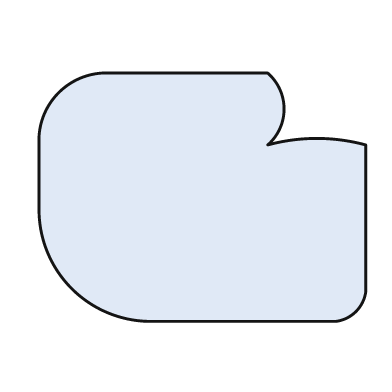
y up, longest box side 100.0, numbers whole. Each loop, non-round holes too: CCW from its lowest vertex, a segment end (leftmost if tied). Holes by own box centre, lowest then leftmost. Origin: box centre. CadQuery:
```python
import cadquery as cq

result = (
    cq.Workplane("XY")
    .moveTo(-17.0, -38.0)
    .lineTo(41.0, -38.0)
    .threePointArc((47.0, -35.0), (50.0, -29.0))
    .lineTo(50.0, 16.0)
    .threePointArc((35.0, 18.0), (20.0, 16.0))
    .threePointArc((25.0, 27.0), (20.0, 38.0))
    .lineTo(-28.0, 38.0)
    .threePointArc((-44.0, 32.0), (-50.0, 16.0))
    .lineTo(-50.0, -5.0)
    .threePointArc((-40.0, -28.0), (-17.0, -38.0))
    .close()
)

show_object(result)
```